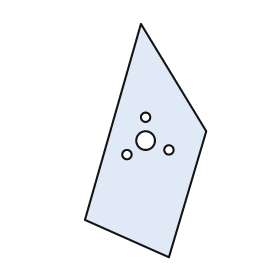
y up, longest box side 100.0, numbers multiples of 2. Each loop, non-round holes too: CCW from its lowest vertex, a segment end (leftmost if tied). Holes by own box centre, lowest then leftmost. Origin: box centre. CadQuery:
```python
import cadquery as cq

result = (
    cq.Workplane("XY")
    .moveTo(10.0, -50.0)
    .lineTo(26.0, 4.0)
    .lineTo(-2.0, 50.0)
    .lineTo(-26.0, -34.0)
    .close()
    .moveTo(-8.0, -6.0)
    .circle(2.0)
    .moveTo(10.0, -4.0)
    .circle(2.0)
    .moveTo(0.0, 0.0)
    .circle(4.0)
    .moveTo(0.0, 10.0)
    .circle(2.0)
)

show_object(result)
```